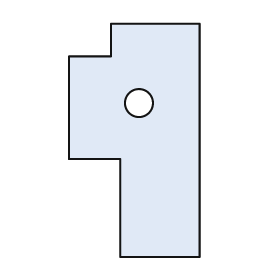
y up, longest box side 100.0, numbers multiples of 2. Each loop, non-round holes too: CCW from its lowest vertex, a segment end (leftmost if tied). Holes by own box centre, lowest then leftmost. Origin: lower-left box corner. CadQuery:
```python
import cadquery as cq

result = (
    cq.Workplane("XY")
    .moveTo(22.0, 0.0)
    .lineTo(56.0, 0.0)
    .lineTo(56.0, 100.0)
    .lineTo(18.0, 100.0)
    .lineTo(18.0, 86.0)
    .lineTo(0.0, 86.0)
    .lineTo(0.0, 42.0)
    .lineTo(22.0, 42.0)
    .close()
    .moveTo(30.0, 66.0)
    .circle(6.0)
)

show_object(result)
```